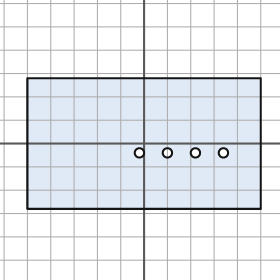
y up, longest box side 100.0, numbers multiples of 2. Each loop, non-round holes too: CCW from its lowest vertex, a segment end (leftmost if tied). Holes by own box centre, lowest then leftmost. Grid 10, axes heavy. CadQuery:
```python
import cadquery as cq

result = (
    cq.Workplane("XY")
    .moveTo(-50.0, -28.0)
    .lineTo(50.0, -28.0)
    .lineTo(50.0, 28.0)
    .lineTo(-50.0, 28.0)
    .close()
    .moveTo(-2.0, -4.0)
    .circle(2.0)
    .moveTo(10.0, -4.0)
    .circle(2.0)
    .moveTo(22.0, -4.0)
    .circle(2.0)
    .moveTo(34.0, -4.0)
    .circle(2.0)
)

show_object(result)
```